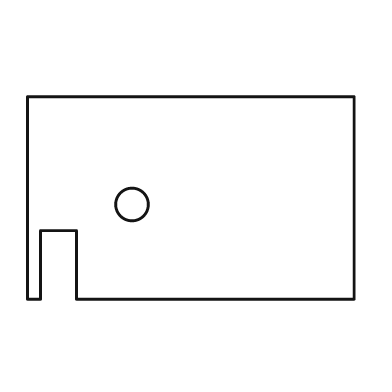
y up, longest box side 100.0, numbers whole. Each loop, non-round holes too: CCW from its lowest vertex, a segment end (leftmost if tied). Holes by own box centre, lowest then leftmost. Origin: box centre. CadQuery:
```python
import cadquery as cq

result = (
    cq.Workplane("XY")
    .moveTo(-50.0, -31.0)
    .lineTo(-46.0, -31.0)
    .lineTo(-46.0, -10.0)
    .lineTo(-35.0, -10.0)
    .lineTo(-35.0, -31.0)
    .lineTo(50.0, -31.0)
    .lineTo(50.0, 31.0)
    .lineTo(-50.0, 31.0)
    .close()
    .moveTo(-18.0, -2.0)
    .circle(5.0)
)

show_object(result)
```